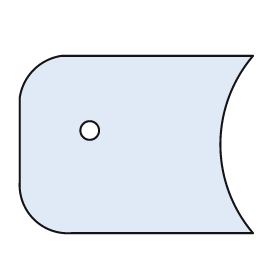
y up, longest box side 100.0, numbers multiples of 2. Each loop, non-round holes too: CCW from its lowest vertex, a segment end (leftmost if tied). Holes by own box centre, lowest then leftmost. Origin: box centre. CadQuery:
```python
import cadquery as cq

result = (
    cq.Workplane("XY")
    .moveTo(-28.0, -38.0)
    .lineTo(50.0, -38.0)
    .threePointArc((36.0, 0.0), (50.0, 38.0))
    .lineTo(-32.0, 38.0)
    .threePointArc((-44.0, 32.0), (-50.0, 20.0))
    .lineTo(-50.0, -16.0)
    .threePointArc((-44.0, -32.0), (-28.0, -38.0))
    .close()
    .moveTo(-20.0, 6.0)
    .circle(4.0)
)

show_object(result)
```